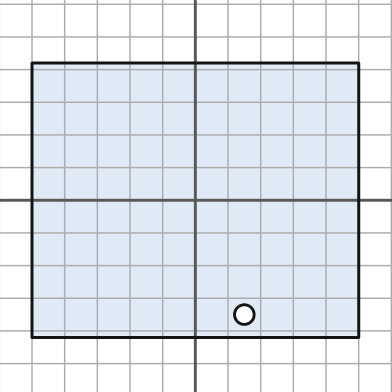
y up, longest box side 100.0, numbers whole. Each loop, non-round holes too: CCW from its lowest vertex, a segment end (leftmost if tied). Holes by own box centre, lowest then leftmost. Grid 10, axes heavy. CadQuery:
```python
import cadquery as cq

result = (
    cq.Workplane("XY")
    .moveTo(-50.0, -42.0)
    .lineTo(50.0, -42.0)
    .lineTo(50.0, 42.0)
    .lineTo(-50.0, 42.0)
    .close()
    .moveTo(15.0, -35.0)
    .circle(3.0)
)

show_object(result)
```